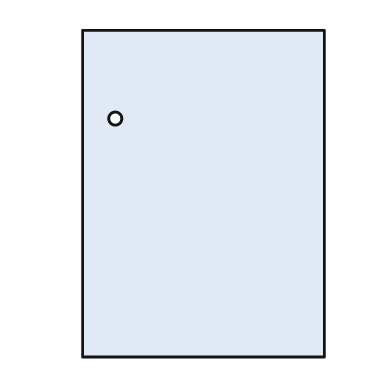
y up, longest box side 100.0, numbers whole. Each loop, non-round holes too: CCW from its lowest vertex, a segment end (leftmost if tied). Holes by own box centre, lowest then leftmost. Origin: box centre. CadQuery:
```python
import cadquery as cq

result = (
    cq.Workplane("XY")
    .moveTo(-37.0, -50.0)
    .lineTo(37.0, -50.0)
    .lineTo(37.0, 50.0)
    .lineTo(-37.0, 50.0)
    .close()
    .moveTo(-27.0, 23.0)
    .circle(2.0)
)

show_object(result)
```